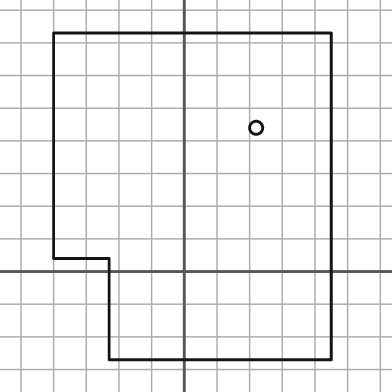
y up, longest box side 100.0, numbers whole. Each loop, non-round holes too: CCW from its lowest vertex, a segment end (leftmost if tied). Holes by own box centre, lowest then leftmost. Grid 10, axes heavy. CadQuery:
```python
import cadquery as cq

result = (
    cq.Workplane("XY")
    .moveTo(-23.0, -27.0)
    .lineTo(45.0, -27.0)
    .lineTo(45.0, 73.0)
    .lineTo(-40.0, 73.0)
    .lineTo(-40.0, 4.0)
    .lineTo(-23.0, 4.0)
    .close()
    .moveTo(22.0, 44.0)
    .circle(2.0)
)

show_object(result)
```